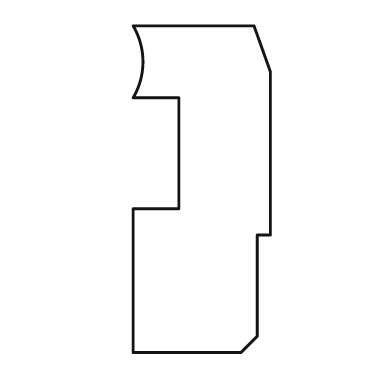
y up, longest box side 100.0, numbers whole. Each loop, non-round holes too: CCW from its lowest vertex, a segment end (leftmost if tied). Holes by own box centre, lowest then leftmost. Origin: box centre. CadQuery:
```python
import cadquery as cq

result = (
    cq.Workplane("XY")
    .moveTo(-21.0, -50.0)
    .lineTo(12.0, -50.0)
    .lineTo(17.0, -45.0)
    .lineTo(17.0, -14.0)
    .lineTo(21.0, -14.0)
    .lineTo(21.0, 36.0)
    .lineTo(16.0, 50.0)
    .lineTo(-21.0, 50.0)
    .threePointArc((-18.0, 39.0), (-21.0, 28.0))
    .lineTo(-7.0, 28.0)
    .lineTo(-7.0, -6.0)
    .lineTo(-21.0, -6.0)
    .close()
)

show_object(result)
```